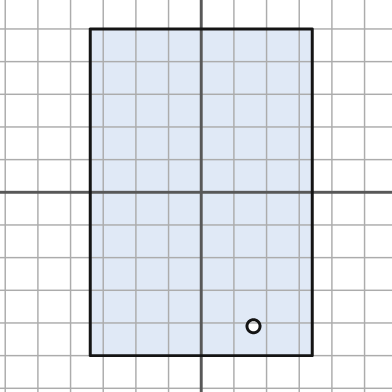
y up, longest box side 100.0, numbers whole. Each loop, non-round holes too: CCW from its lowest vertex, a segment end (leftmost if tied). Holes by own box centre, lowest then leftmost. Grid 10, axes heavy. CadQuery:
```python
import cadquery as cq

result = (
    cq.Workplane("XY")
    .moveTo(-34.0, -50.0)
    .lineTo(34.0, -50.0)
    .lineTo(34.0, 50.0)
    .lineTo(-34.0, 50.0)
    .close()
    .moveTo(16.0, -41.0)
    .circle(2.0)
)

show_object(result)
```